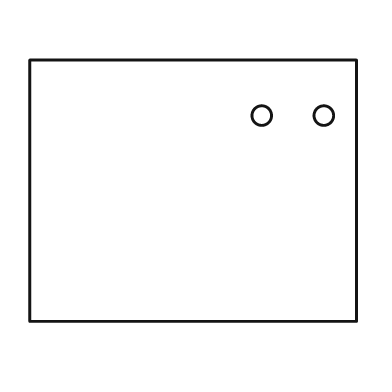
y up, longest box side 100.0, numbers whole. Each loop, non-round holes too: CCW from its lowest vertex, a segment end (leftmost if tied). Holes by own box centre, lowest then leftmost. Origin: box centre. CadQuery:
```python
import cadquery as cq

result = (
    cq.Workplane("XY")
    .moveTo(-50.0, -40.0)
    .lineTo(50.0, -40.0)
    .lineTo(50.0, 40.0)
    .lineTo(-50.0, 40.0)
    .close()
    .moveTo(21.0, 23.0)
    .circle(3.0)
    .moveTo(40.0, 23.0)
    .circle(3.0)
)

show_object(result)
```